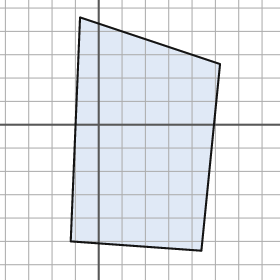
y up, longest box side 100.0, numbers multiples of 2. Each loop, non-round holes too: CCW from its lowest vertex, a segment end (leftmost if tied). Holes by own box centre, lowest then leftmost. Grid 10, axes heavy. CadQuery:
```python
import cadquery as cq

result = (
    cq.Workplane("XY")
    .moveTo(44.0, -54.0)
    .lineTo(52.0, 26.0)
    .lineTo(-8.0, 46.0)
    .lineTo(-12.0, -50.0)
    .close()
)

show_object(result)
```